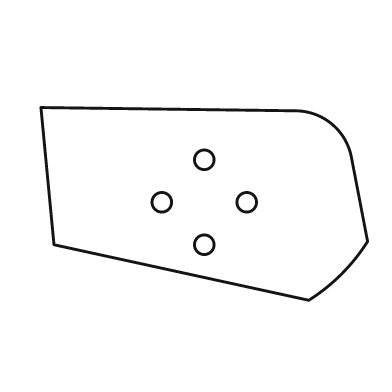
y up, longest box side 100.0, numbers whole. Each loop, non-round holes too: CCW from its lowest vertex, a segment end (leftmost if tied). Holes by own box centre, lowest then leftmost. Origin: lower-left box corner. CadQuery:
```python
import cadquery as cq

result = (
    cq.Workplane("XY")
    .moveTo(82.0, 0.0)
    .threePointArc((92.0, 8.0), (100.0, 18.0))
    .lineTo(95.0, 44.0)
    .threePointArc((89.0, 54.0), (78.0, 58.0))
    .lineTo(0.0, 59.0)
    .lineTo(4.0, 17.0)
    .close()
    .moveTo(50.0, 17.0)
    .circle(3.0)
    .moveTo(37.0, 30.0)
    .circle(3.0)
    .moveTo(63.0, 30.0)
    .circle(3.0)
    .moveTo(50.0, 43.0)
    .circle(3.0)
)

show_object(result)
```